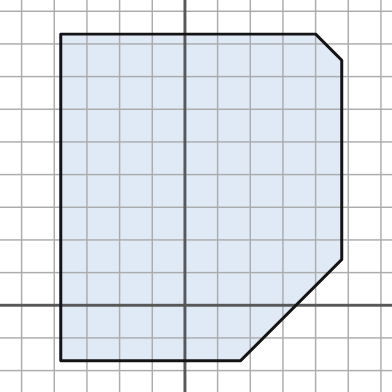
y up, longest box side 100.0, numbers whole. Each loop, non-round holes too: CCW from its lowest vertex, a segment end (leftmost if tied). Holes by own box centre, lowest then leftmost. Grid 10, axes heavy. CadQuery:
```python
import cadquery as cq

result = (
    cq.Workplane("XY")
    .moveTo(-38.0, -17.0)
    .lineTo(17.0, -17.0)
    .lineTo(48.0, 14.0)
    .lineTo(48.0, 75.0)
    .lineTo(40.0, 83.0)
    .lineTo(-38.0, 83.0)
    .close()
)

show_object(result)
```